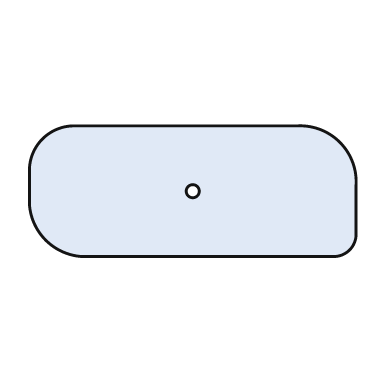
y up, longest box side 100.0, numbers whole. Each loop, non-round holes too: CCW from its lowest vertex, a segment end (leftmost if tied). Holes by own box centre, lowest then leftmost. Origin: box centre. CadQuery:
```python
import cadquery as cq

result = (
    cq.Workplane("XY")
    .moveTo(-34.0, -20.0)
    .lineTo(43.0, -20.0)
    .threePointArc((48.0, -18.0), (50.0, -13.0))
    .lineTo(50.0, 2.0)
    .threePointArc((45.0, 15.0), (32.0, 20.0))
    .lineTo(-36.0, 20.0)
    .threePointArc((-46.0, 16.0), (-50.0, 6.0))
    .lineTo(-50.0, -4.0)
    .threePointArc((-45.0, -15.0), (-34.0, -20.0))
    .close()
    .moveTo(0.0, 0.0)
    .circle(2.0)
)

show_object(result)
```